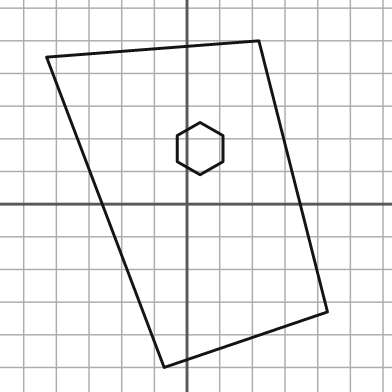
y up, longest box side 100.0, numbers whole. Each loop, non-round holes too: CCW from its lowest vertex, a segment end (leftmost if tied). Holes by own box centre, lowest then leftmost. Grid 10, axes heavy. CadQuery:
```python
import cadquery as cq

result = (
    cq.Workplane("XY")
    .moveTo(-7.0, -50.0)
    .lineTo(43.0, -33.0)
    .lineTo(22.0, 50.0)
    .lineTo(-43.0, 45.0)
    .close()
    .moveTo(4.0, 9.0)
    .lineTo(11.0, 13.0)
    .lineTo(11.0, 21.0)
    .lineTo(4.0, 25.0)
    .lineTo(-3.0, 21.0)
    .lineTo(-3.0, 13.0)
    .close()
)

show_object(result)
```